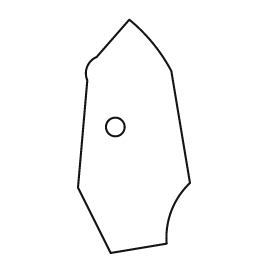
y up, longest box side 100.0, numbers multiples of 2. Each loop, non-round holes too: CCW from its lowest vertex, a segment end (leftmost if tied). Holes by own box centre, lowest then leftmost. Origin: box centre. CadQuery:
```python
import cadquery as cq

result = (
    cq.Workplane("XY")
    .moveTo(-10.0, -50.0)
    .lineTo(14.0, -46.0)
    .threePointArc((16.0, -32.0), (24.0, -20.0))
    .lineTo(16.0, 28.0)
    .threePointArc((8.0, 40.0), (-2.0, 50.0))
    .lineTo(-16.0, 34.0)
    .threePointArc((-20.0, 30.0), (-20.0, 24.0))
    .lineTo(-24.0, -22.0)
    .close()
    .moveTo(-8.0, 4.0)
    .circle(4.0)
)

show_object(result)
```